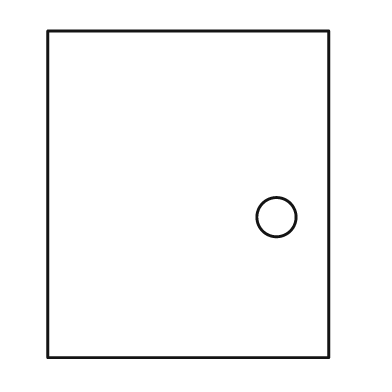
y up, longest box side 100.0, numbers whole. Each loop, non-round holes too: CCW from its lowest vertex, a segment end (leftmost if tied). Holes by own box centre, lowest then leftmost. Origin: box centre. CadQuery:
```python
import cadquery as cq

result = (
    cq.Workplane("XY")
    .moveTo(-43.0, -50.0)
    .lineTo(43.0, -50.0)
    .lineTo(43.0, 50.0)
    .lineTo(-43.0, 50.0)
    .close()
    .moveTo(27.0, -7.0)
    .circle(6.0)
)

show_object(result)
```